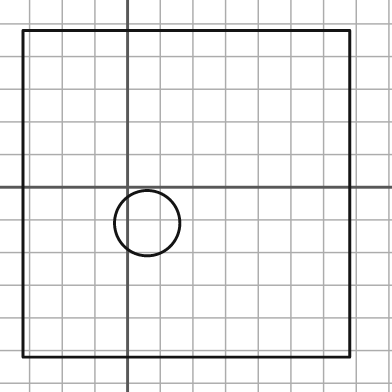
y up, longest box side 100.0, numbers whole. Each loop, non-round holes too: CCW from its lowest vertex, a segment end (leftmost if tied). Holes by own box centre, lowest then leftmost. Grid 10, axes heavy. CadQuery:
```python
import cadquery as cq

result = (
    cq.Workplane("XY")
    .moveTo(-32.0, -52.0)
    .lineTo(68.0, -52.0)
    .lineTo(68.0, 48.0)
    .lineTo(-32.0, 48.0)
    .close()
    .moveTo(6.0, -11.0)
    .circle(10.0)
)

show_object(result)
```